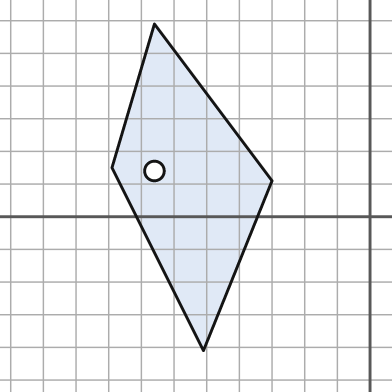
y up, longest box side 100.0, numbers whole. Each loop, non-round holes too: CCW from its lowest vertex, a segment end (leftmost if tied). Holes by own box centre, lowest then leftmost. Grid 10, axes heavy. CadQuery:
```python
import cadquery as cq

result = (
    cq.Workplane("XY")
    .moveTo(-51.0, -41.0)
    .lineTo(-30.0, 11.0)
    .lineTo(-66.0, 59.0)
    .lineTo(-79.0, 15.0)
    .close()
    .moveTo(-66.0, 14.0)
    .circle(3.0)
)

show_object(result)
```